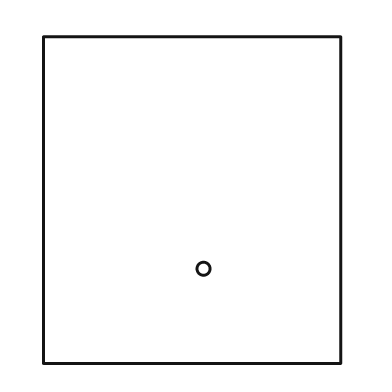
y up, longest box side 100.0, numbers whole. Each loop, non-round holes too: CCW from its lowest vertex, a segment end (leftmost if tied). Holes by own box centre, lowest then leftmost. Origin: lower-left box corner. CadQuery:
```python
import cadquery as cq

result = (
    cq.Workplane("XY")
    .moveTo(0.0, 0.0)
    .lineTo(91.0, 0.0)
    .lineTo(91.0, 100.0)
    .lineTo(0.0, 100.0)
    .close()
    .moveTo(49.0, 29.0)
    .circle(2.0)
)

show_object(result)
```